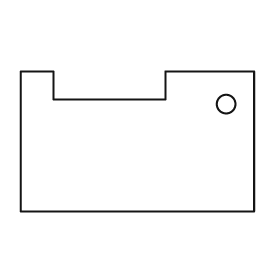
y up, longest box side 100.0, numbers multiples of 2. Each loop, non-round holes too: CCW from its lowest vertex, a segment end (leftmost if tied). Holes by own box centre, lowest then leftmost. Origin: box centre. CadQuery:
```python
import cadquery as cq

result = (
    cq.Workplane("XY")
    .moveTo(-50.0, -30.0)
    .lineTo(50.0, -30.0)
    .lineTo(50.0, 30.0)
    .lineTo(12.0, 30.0)
    .lineTo(12.0, 18.0)
    .lineTo(-36.0, 18.0)
    .lineTo(-36.0, 30.0)
    .lineTo(-50.0, 30.0)
    .close()
    .moveTo(38.0, 16.0)
    .circle(4.0)
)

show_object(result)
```